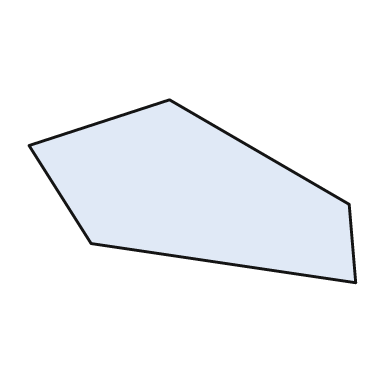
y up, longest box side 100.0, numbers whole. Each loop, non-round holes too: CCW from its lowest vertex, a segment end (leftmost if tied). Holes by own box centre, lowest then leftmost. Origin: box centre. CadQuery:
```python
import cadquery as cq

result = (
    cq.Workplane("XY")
    .moveTo(50.0, -28.0)
    .lineTo(48.0, -4.0)
    .lineTo(-7.0, 28.0)
    .lineTo(-50.0, 14.0)
    .lineTo(-31.0, -16.0)
    .close()
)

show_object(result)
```